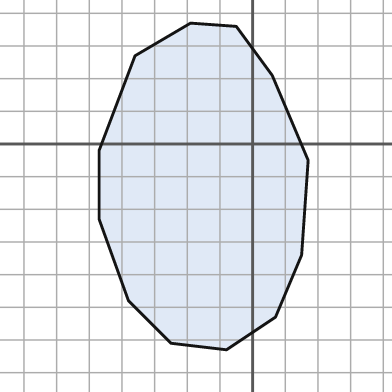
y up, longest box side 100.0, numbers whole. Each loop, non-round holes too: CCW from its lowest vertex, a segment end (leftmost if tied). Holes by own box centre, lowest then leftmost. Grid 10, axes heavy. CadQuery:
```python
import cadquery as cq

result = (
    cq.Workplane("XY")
    .moveTo(-8.0, -63.0)
    .lineTo(7.0, -53.0)
    .lineTo(15.0, -34.0)
    .lineTo(17.0, -5.0)
    .lineTo(6.0, 21.0)
    .lineTo(-5.0, 36.0)
    .lineTo(-19.0, 37.0)
    .lineTo(-36.0, 27.0)
    .lineTo(-47.0, -2.0)
    .lineTo(-47.0, -23.0)
    .lineTo(-38.0, -48.0)
    .lineTo(-25.0, -61.0)
    .close()
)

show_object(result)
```